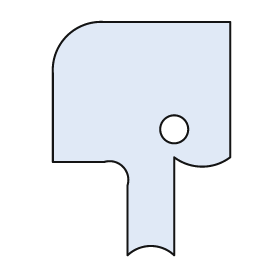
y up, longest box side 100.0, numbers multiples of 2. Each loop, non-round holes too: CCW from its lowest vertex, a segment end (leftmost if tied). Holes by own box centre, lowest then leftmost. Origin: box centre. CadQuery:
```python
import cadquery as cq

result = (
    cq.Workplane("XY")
    .moveTo(-6.0, -50.0)
    .threePointArc((4.0, -46.0), (14.0, -50.0))
    .lineTo(14.0, -8.0)
    .threePointArc((26.0, -12.0), (38.0, -8.0))
    .lineTo(38.0, 50.0)
    .lineTo(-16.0, 50.0)
    .threePointArc((-32.0, 44.0), (-38.0, 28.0))
    .lineTo(-38.0, -10.0)
    .lineTo(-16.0, -10.0)
    .threePointArc((-8.0, -12.0), (-6.0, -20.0))
    .close()
    .moveTo(14.0, 4.0)
    .circle(6.0)
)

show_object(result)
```